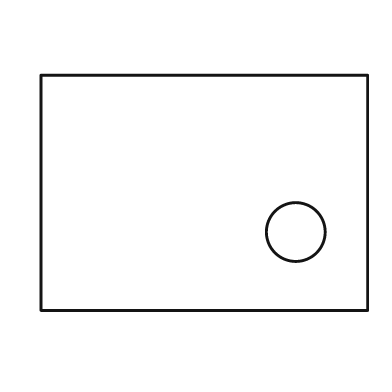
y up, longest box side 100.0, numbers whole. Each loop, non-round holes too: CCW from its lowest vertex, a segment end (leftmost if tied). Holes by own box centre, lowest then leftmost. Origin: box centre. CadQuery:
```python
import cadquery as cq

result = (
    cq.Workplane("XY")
    .moveTo(-50.0, -36.0)
    .lineTo(50.0, -36.0)
    .lineTo(50.0, 36.0)
    .lineTo(-50.0, 36.0)
    .close()
    .moveTo(28.0, -12.0)
    .circle(9.0)
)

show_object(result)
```